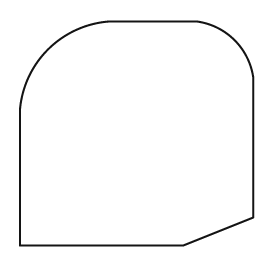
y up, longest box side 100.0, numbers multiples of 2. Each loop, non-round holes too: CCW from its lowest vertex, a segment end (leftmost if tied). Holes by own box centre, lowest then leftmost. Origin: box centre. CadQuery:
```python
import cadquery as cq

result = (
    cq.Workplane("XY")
    .moveTo(-50.0, -48.0)
    .lineTo(20.0, -48.0)
    .lineTo(50.0, -36.0)
    .lineTo(50.0, 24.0)
    .threePointArc((42.0, 40.0), (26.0, 48.0))
    .lineTo(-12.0, 48.0)
    .threePointArc((-38.0, 36.0), (-50.0, 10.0))
    .close()
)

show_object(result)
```